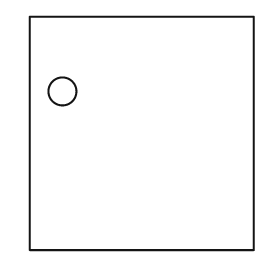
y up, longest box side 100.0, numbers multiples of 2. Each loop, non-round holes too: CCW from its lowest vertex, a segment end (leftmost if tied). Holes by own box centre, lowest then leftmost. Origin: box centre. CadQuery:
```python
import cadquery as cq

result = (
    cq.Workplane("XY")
    .moveTo(-48.0, -50.0)
    .lineTo(48.0, -50.0)
    .lineTo(48.0, 50.0)
    .lineTo(-48.0, 50.0)
    .close()
    .moveTo(-34.0, 18.0)
    .circle(6.0)
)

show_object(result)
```